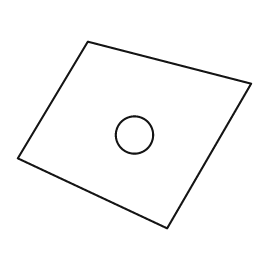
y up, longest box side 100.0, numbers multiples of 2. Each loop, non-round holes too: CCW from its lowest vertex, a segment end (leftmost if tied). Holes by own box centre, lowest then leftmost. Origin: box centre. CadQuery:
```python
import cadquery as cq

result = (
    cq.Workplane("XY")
    .moveTo(14.0, -40.0)
    .lineTo(50.0, 22.0)
    .lineTo(-20.0, 40.0)
    .lineTo(-50.0, -10.0)
    .close()
    .moveTo(0.0, 0.0)
    .circle(8.0)
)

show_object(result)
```